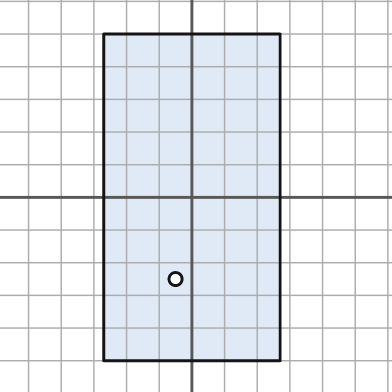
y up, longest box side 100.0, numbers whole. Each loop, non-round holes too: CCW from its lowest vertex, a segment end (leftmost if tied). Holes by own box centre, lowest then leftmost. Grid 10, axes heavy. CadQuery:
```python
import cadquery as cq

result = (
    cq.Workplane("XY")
    .moveTo(-27.0, -50.0)
    .lineTo(27.0, -50.0)
    .lineTo(27.0, 50.0)
    .lineTo(-27.0, 50.0)
    .close()
    .moveTo(-5.0, -25.0)
    .circle(2.0)
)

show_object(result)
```